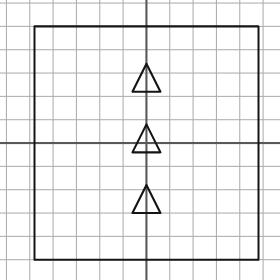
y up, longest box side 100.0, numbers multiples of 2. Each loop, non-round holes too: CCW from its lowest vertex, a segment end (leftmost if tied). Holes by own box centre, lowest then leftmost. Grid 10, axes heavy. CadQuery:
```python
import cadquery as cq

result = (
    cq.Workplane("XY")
    .moveTo(-48.0, -50.0)
    .lineTo(48.0, -50.0)
    .lineTo(48.0, 50.0)
    .lineTo(-48.0, 50.0)
    .close()
    .moveTo(-6.0, -30.0)
    .lineTo(6.0, -30.0)
    .lineTo(0.0, -18.0)
    .close()
    .moveTo(-6.0, -4.0)
    .lineTo(6.0, -4.0)
    .lineTo(0.0, 8.0)
    .close()
    .moveTo(-6.0, 22.0)
    .lineTo(6.0, 22.0)
    .lineTo(0.0, 34.0)
    .close()
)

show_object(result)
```